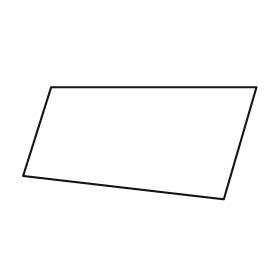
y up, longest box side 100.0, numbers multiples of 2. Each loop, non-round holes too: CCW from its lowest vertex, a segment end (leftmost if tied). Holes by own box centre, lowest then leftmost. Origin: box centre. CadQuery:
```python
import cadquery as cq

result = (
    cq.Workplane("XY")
    .moveTo(36.0, -24.0)
    .lineTo(50.0, 24.0)
    .lineTo(-38.0, 24.0)
    .lineTo(-50.0, -14.0)
    .close()
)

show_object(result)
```